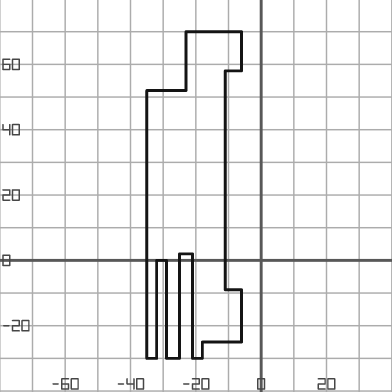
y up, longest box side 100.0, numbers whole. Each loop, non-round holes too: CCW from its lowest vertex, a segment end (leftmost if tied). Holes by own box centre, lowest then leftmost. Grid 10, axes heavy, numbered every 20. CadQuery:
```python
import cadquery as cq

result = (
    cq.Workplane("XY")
    .moveTo(-35.0, -30.0)
    .lineTo(-32.0, -30.0)
    .lineTo(-32.0, 0.0)
    .lineTo(-29.0, 0.0)
    .lineTo(-29.0, -30.0)
    .lineTo(-25.0, -30.0)
    .lineTo(-25.0, 2.0)
    .lineTo(-21.0, 2.0)
    .lineTo(-21.0, -30.0)
    .lineTo(-18.0, -30.0)
    .lineTo(-18.0, -25.0)
    .lineTo(-6.0, -25.0)
    .lineTo(-6.0, -9.0)
    .lineTo(-11.0, -9.0)
    .lineTo(-11.0, 58.0)
    .lineTo(-6.0, 58.0)
    .lineTo(-6.0, 70.0)
    .lineTo(-23.0, 70.0)
    .lineTo(-23.0, 52.0)
    .lineTo(-35.0, 52.0)
    .close()
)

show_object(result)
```